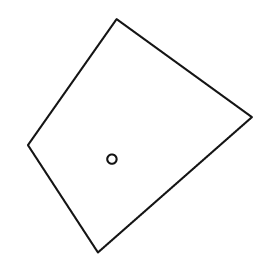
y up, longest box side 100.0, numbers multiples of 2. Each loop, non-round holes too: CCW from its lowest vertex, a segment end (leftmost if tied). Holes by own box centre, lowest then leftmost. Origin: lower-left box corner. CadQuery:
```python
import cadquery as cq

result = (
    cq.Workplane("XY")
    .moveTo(30.0, 0.0)
    .lineTo(96.0, 58.0)
    .lineTo(38.0, 100.0)
    .lineTo(0.0, 46.0)
    .close()
    .moveTo(36.0, 40.0)
    .circle(2.0)
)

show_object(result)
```